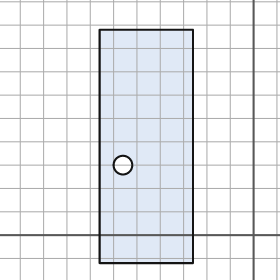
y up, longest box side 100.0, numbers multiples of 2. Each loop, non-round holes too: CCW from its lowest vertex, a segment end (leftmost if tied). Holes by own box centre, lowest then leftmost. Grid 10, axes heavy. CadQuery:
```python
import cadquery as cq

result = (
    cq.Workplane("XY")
    .moveTo(-66.0, -12.0)
    .lineTo(-26.0, -12.0)
    .lineTo(-26.0, 88.0)
    .lineTo(-66.0, 88.0)
    .close()
    .moveTo(-56.0, 30.0)
    .circle(4.0)
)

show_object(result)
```